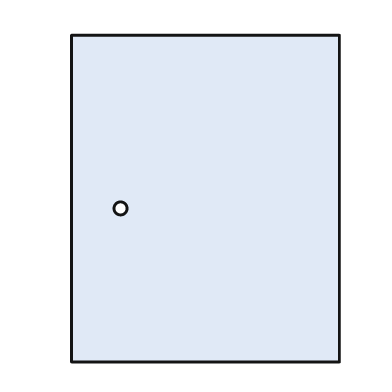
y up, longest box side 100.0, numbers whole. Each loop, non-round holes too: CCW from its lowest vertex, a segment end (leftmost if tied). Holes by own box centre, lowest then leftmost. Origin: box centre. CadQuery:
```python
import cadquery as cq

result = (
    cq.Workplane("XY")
    .moveTo(-41.0, -50.0)
    .lineTo(41.0, -50.0)
    .lineTo(41.0, 50.0)
    .lineTo(-41.0, 50.0)
    .close()
    .moveTo(-26.0, -3.0)
    .circle(2.0)
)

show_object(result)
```